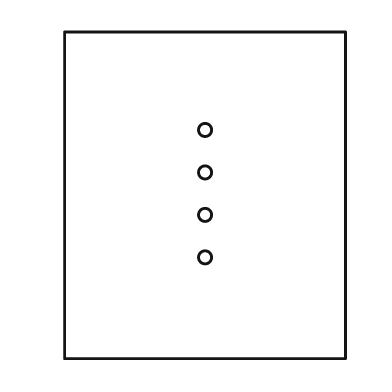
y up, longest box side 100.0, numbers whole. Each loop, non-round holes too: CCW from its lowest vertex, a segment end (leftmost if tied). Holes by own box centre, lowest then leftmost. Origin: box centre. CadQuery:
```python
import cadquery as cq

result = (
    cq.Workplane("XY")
    .moveTo(-43.0, -50.0)
    .lineTo(43.0, -50.0)
    .lineTo(43.0, 50.0)
    .lineTo(-43.0, 50.0)
    .close()
    .moveTo(0.0, -19.0)
    .circle(2.0)
    .moveTo(0.0, -6.0)
    .circle(2.0)
    .moveTo(0.0, 7.0)
    .circle(2.0)
    .moveTo(0.0, 20.0)
    .circle(2.0)
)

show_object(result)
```